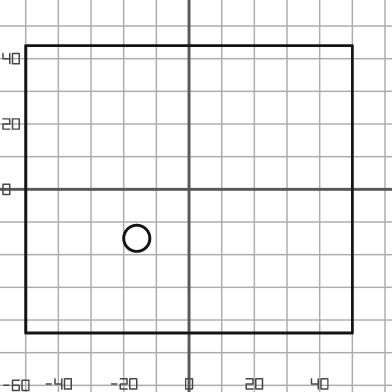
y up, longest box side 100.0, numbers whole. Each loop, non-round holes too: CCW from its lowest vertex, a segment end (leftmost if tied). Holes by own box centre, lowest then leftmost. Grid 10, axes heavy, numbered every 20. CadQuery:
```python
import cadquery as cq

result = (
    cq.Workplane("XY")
    .moveTo(-50.0, -44.0)
    .lineTo(50.0, -44.0)
    .lineTo(50.0, 44.0)
    .lineTo(-50.0, 44.0)
    .close()
    .moveTo(-16.0, -15.0)
    .circle(4.0)
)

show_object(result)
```